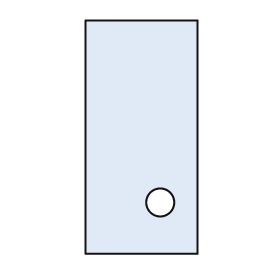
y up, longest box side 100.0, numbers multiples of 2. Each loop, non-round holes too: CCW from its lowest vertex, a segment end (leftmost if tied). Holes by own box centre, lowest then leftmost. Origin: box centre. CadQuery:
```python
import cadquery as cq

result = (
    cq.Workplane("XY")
    .moveTo(-24.0, -50.0)
    .lineTo(24.0, -50.0)
    .lineTo(24.0, 50.0)
    .lineTo(-24.0, 50.0)
    .close()
    .moveTo(8.0, -28.0)
    .circle(6.0)
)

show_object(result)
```